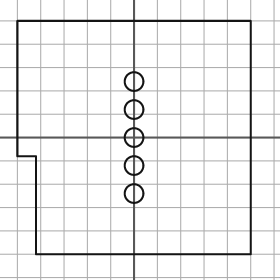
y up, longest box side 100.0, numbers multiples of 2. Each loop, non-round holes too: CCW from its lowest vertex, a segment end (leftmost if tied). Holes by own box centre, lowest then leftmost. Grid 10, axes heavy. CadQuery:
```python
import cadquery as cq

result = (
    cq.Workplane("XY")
    .moveTo(-42.0, -50.0)
    .lineTo(50.0, -50.0)
    .lineTo(50.0, 50.0)
    .lineTo(-50.0, 50.0)
    .lineTo(-50.0, -8.0)
    .lineTo(-42.0, -8.0)
    .close()
    .moveTo(0.0, -24.0)
    .circle(4.0)
    .moveTo(0.0, -12.0)
    .circle(4.0)
    .moveTo(0.0, 0.0)
    .circle(4.0)
    .moveTo(0.0, 12.0)
    .circle(4.0)
    .moveTo(0.0, 24.0)
    .circle(4.0)
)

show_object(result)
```